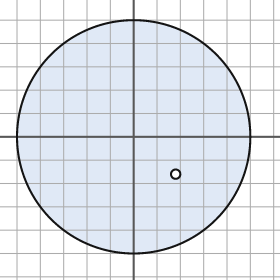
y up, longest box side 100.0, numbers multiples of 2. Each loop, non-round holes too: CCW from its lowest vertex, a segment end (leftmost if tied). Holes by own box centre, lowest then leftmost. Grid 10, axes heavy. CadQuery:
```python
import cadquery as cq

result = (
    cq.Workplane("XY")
    .moveTo(0.0, 0.0)
    .circle(50.0)
    .moveTo(18.0, -16.0)
    .circle(2.0)
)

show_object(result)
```